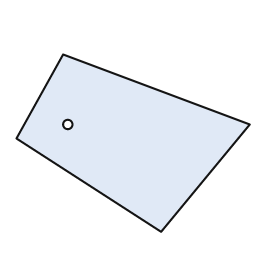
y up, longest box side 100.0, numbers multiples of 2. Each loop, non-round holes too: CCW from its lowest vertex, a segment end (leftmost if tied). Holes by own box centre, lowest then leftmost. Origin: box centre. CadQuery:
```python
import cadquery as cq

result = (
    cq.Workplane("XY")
    .moveTo(12.0, -38.0)
    .lineTo(50.0, 8.0)
    .lineTo(-30.0, 38.0)
    .lineTo(-50.0, 2.0)
    .close()
    .moveTo(-28.0, 8.0)
    .circle(2.0)
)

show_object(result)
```